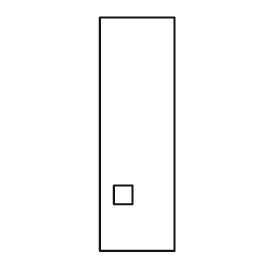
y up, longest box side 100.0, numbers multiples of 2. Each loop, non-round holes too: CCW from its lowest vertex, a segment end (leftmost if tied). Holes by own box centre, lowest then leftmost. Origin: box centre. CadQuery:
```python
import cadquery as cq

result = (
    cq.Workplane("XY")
    .moveTo(-16.0, -50.0)
    .lineTo(16.0, -50.0)
    .lineTo(16.0, 50.0)
    .lineTo(-16.0, 50.0)
    .close()
    .moveTo(-10.0, -30.0)
    .lineTo(-2.0, -30.0)
    .lineTo(-2.0, -22.0)
    .lineTo(-10.0, -22.0)
    .close()
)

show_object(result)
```